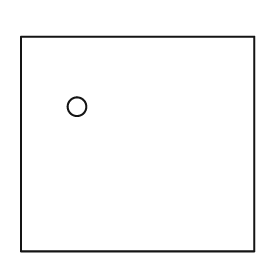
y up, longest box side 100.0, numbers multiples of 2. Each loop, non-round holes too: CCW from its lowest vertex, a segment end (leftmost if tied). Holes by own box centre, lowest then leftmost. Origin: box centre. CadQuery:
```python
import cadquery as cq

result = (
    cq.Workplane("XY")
    .moveTo(-50.0, -46.0)
    .lineTo(50.0, -46.0)
    .lineTo(50.0, 46.0)
    .lineTo(-50.0, 46.0)
    .close()
    .moveTo(-26.0, 16.0)
    .circle(4.0)
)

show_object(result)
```